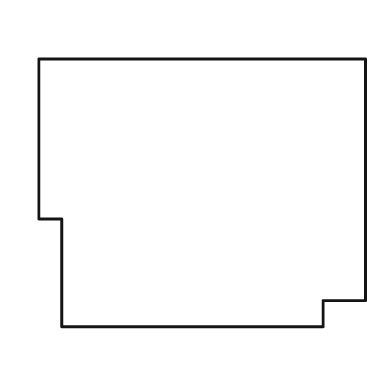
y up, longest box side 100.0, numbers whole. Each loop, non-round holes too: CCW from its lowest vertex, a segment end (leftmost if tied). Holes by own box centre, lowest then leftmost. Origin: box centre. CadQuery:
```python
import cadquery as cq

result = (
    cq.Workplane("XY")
    .moveTo(-43.0, -41.0)
    .lineTo(37.0, -41.0)
    .lineTo(37.0, -33.0)
    .lineTo(50.0, -33.0)
    .lineTo(50.0, 41.0)
    .lineTo(-50.0, 41.0)
    .lineTo(-50.0, -8.0)
    .lineTo(-43.0, -8.0)
    .close()
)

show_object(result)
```